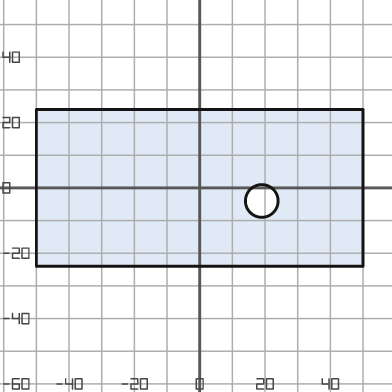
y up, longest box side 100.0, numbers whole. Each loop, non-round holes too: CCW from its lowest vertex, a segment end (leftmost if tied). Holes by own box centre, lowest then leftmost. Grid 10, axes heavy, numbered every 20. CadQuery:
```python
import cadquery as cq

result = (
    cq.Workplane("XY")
    .moveTo(-50.0, -24.0)
    .lineTo(50.0, -24.0)
    .lineTo(50.0, 24.0)
    .lineTo(-50.0, 24.0)
    .close()
    .moveTo(19.0, -4.0)
    .circle(5.0)
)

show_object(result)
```